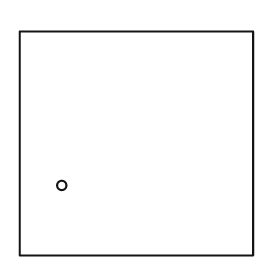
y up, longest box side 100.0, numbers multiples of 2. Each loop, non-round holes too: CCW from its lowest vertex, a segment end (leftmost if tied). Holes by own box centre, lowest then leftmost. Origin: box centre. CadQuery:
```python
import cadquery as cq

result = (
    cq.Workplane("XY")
    .moveTo(-50.0, -48.0)
    .lineTo(50.0, -48.0)
    .lineTo(50.0, 48.0)
    .lineTo(-50.0, 48.0)
    .close()
    .moveTo(-32.0, -18.0)
    .circle(2.0)
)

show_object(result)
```